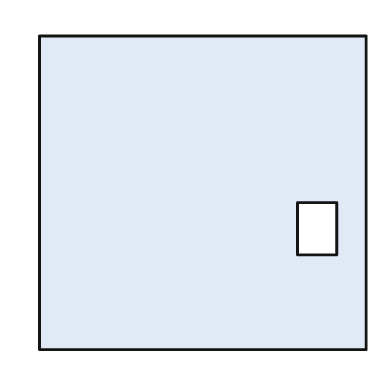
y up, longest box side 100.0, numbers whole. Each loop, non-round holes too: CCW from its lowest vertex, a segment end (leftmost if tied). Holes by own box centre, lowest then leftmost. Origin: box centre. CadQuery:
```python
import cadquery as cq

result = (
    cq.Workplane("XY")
    .moveTo(-50.0, -48.0)
    .lineTo(50.0, -48.0)
    .lineTo(50.0, 48.0)
    .lineTo(-50.0, 48.0)
    .close()
    .moveTo(29.0, -19.0)
    .lineTo(41.0, -19.0)
    .lineTo(41.0, -3.0)
    .lineTo(29.0, -3.0)
    .close()
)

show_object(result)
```